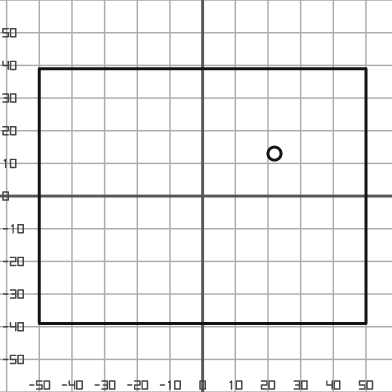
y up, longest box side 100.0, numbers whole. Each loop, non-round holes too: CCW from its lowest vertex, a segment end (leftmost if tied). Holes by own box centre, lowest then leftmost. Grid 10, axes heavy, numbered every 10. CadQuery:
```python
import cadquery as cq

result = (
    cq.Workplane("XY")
    .moveTo(-50.0, -39.0)
    .lineTo(50.0, -39.0)
    .lineTo(50.0, 39.0)
    .lineTo(-50.0, 39.0)
    .close()
    .moveTo(22.0, 13.0)
    .circle(2.0)
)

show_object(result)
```